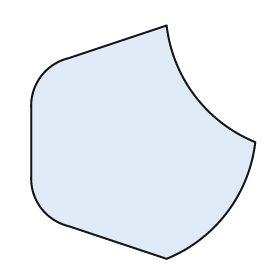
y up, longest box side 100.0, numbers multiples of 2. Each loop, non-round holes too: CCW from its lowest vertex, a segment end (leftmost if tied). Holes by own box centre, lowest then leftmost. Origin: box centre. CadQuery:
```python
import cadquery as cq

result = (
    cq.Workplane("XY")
    .moveTo(10.0, -50.0)
    .threePointArc((36.0, -30.0), (48.0, 0.0))
    .threePointArc((22.0, 20.0), (10.0, 50.0))
    .lineTo(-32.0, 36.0)
    .threePointArc((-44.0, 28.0), (-48.0, 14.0))
    .lineTo(-48.0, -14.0)
    .threePointArc((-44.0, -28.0), (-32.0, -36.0))
    .close()
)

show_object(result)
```